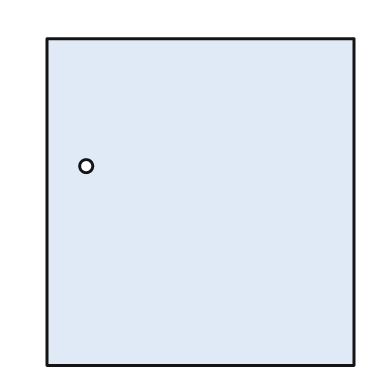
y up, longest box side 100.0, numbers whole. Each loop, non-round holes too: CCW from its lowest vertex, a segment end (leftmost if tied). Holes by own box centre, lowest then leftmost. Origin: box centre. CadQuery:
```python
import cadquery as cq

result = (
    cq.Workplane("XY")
    .moveTo(-47.0, -50.0)
    .lineTo(47.0, -50.0)
    .lineTo(47.0, 50.0)
    .lineTo(-47.0, 50.0)
    .close()
    .moveTo(-35.0, 11.0)
    .circle(2.0)
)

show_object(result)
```